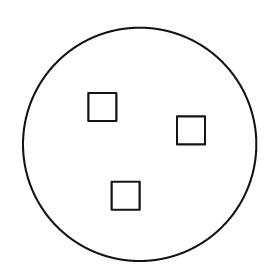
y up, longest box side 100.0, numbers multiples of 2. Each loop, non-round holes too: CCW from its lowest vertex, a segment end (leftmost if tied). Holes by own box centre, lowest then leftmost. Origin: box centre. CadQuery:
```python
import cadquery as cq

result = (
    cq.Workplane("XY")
    .moveTo(0.0, 0.0)
    .circle(50.0)
    .moveTo(-12.0, -28.0)
    .lineTo(0.0, -28.0)
    .lineTo(0.0, -16.0)
    .lineTo(-12.0, -16.0)
    .close()
    .moveTo(16.0, 0.0)
    .lineTo(28.0, 0.0)
    .lineTo(28.0, 12.0)
    .lineTo(16.0, 12.0)
    .close()
    .moveTo(-22.0, 10.0)
    .lineTo(-10.0, 10.0)
    .lineTo(-10.0, 22.0)
    .lineTo(-22.0, 22.0)
    .close()
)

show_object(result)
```